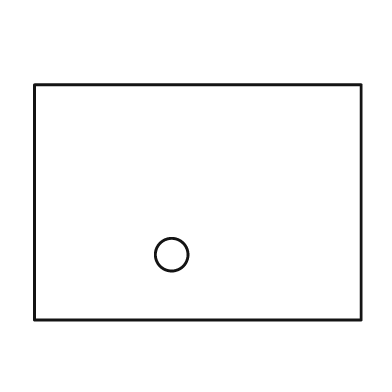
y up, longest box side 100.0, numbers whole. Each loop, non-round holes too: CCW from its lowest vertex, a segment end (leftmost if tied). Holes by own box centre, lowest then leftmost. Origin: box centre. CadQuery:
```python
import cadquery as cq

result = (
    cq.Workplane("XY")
    .moveTo(-50.0, -36.0)
    .lineTo(50.0, -36.0)
    .lineTo(50.0, 36.0)
    .lineTo(-50.0, 36.0)
    .close()
    .moveTo(-8.0, -16.0)
    .circle(5.0)
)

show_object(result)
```